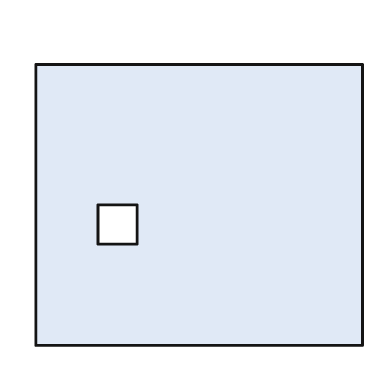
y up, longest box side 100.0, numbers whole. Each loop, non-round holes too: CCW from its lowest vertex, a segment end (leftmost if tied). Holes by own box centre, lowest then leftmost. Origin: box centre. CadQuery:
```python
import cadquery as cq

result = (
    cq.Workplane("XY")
    .moveTo(-50.0, -43.0)
    .lineTo(50.0, -43.0)
    .lineTo(50.0, 43.0)
    .lineTo(-50.0, 43.0)
    .close()
    .moveTo(-31.0, -12.0)
    .lineTo(-19.0, -12.0)
    .lineTo(-19.0, 0.0)
    .lineTo(-31.0, 0.0)
    .close()
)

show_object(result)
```